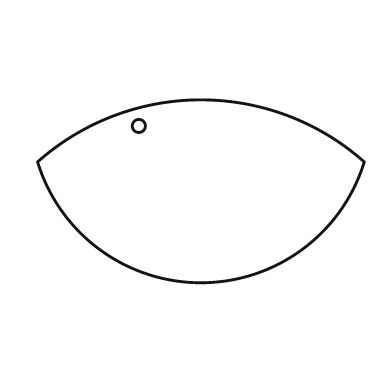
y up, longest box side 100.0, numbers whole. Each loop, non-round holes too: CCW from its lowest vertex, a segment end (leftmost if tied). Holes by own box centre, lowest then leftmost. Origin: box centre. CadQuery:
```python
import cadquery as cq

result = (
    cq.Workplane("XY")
    .moveTo(-50.0, 9.0)
    .threePointArc((0.0, -28.0), (50.0, 9.0))
    .threePointArc((0.0, 28.0), (-50.0, 9.0))
    .close()
    .moveTo(-19.0, 20.0)
    .circle(2.0)
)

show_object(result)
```